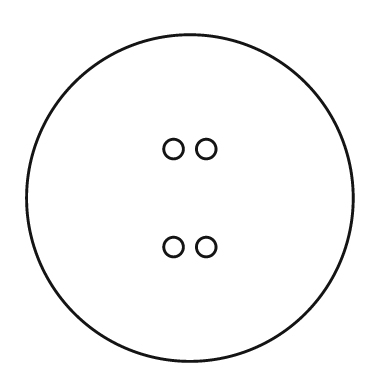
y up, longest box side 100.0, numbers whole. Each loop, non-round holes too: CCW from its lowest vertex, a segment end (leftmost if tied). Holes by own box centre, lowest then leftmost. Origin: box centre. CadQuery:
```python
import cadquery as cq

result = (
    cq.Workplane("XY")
    .moveTo(0.0, 0.0)
    .circle(50.0)
    .moveTo(-5.0, -15.0)
    .circle(3.0)
    .moveTo(5.0, -15.0)
    .circle(3.0)
    .moveTo(-5.0, 15.0)
    .circle(3.0)
    .moveTo(5.0, 15.0)
    .circle(3.0)
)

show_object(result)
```